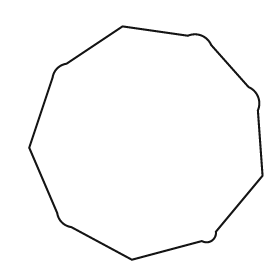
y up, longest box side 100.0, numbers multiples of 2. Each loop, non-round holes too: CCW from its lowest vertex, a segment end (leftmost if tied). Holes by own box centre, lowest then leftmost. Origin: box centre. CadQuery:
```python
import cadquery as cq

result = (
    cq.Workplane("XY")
    .moveTo(-6.0, -50.0)
    .lineTo(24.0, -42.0)
    .threePointArc((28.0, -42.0), (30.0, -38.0))
    .lineTo(50.0, -14.0)
    .lineTo(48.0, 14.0)
    .threePointArc((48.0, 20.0), (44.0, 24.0))
    .lineTo(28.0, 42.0)
    .threePointArc((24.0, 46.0), (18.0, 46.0))
    .lineTo(-10.0, 50.0)
    .lineTo(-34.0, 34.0)
    .threePointArc((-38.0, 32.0), (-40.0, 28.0))
    .lineTo(-50.0, -2.0)
    .lineTo(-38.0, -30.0)
    .threePointArc((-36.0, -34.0), (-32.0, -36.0))
    .close()
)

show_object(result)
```